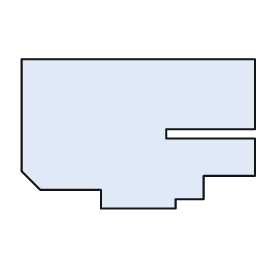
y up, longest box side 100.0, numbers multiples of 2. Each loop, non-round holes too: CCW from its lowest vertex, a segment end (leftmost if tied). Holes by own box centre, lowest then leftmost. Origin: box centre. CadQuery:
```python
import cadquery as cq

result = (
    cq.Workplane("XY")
    .moveTo(-16.0, -32.0)
    .lineTo(16.0, -32.0)
    .lineTo(16.0, -28.0)
    .lineTo(28.0, -28.0)
    .lineTo(28.0, -18.0)
    .lineTo(50.0, -18.0)
    .lineTo(50.0, -2.0)
    .lineTo(12.0, -2.0)
    .lineTo(12.0, 2.0)
    .lineTo(50.0, 2.0)
    .lineTo(50.0, 32.0)
    .lineTo(-50.0, 32.0)
    .lineTo(-50.0, -16.0)
    .lineTo(-42.0, -24.0)
    .lineTo(-16.0, -24.0)
    .close()
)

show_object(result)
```